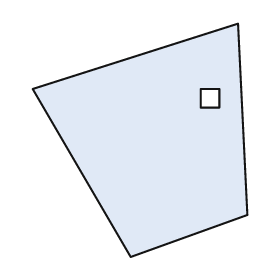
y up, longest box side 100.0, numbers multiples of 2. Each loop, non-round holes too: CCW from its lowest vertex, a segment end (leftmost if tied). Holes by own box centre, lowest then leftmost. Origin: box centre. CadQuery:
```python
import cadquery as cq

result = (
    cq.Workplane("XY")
    .moveTo(-4.0, -50.0)
    .lineTo(46.0, -32.0)
    .lineTo(42.0, 50.0)
    .lineTo(-46.0, 22.0)
    .close()
    .moveTo(26.0, 14.0)
    .lineTo(34.0, 14.0)
    .lineTo(34.0, 22.0)
    .lineTo(26.0, 22.0)
    .close()
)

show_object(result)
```